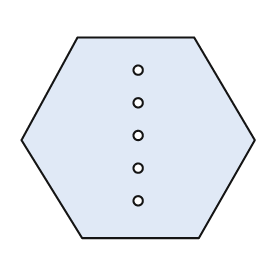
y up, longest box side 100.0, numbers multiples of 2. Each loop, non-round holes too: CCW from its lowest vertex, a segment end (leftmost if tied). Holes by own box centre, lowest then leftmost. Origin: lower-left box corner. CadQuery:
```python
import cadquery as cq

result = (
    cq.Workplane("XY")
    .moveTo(26.0, 0.0)
    .lineTo(76.0, 0.0)
    .lineTo(100.0, 42.0)
    .lineTo(74.0, 86.0)
    .lineTo(24.0, 86.0)
    .lineTo(0.0, 42.0)
    .close()
    .moveTo(50.0, 16.0)
    .circle(2.0)
    .moveTo(50.0, 30.0)
    .circle(2.0)
    .moveTo(50.0, 44.0)
    .circle(2.0)
    .moveTo(50.0, 58.0)
    .circle(2.0)
    .moveTo(50.0, 72.0)
    .circle(2.0)
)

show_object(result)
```